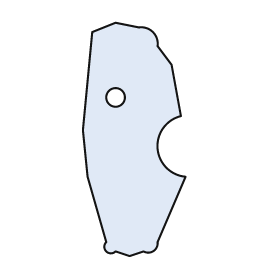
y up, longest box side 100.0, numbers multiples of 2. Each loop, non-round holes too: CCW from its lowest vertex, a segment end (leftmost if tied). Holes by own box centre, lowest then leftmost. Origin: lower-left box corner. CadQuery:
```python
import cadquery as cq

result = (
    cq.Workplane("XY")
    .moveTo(20.0, 0.0)
    .lineTo(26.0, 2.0)
    .threePointArc((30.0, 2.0), (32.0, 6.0))
    .lineTo(44.0, 34.0)
    .threePointArc((32.0, 46.0), (42.0, 60.0))
    .lineTo(38.0, 82.0)
    .lineTo(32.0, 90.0)
    .threePointArc((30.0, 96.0), (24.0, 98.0))
    .lineTo(14.0, 100.0)
    .lineTo(4.0, 96.0)
    .lineTo(0.0, 54.0)
    .lineTo(2.0, 34.0)
    .lineTo(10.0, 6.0)
    .threePointArc((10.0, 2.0), (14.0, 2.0))
    .close()
    .moveTo(14.0, 68.0)
    .circle(4.0)
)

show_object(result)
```